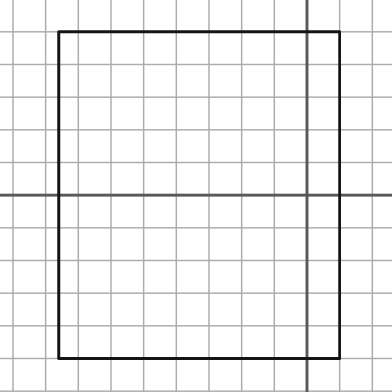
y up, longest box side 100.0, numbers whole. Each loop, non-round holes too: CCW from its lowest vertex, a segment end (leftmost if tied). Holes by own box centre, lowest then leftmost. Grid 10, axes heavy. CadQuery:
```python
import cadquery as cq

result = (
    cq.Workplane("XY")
    .moveTo(-76.0, -50.0)
    .lineTo(10.0, -50.0)
    .lineTo(10.0, 50.0)
    .lineTo(-76.0, 50.0)
    .close()
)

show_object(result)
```